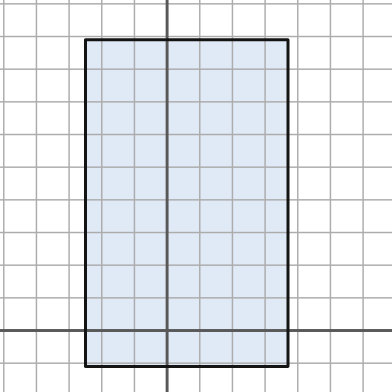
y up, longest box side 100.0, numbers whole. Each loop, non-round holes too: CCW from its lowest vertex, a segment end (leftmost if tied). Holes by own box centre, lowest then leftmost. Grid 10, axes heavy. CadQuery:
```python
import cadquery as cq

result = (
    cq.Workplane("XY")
    .moveTo(-25.0, -11.0)
    .lineTo(37.0, -11.0)
    .lineTo(37.0, 89.0)
    .lineTo(-25.0, 89.0)
    .close()
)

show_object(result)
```